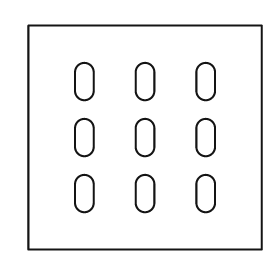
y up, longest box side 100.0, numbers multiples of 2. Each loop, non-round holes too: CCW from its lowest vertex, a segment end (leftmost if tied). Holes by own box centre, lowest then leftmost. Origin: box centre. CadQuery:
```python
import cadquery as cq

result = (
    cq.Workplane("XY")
    .moveTo(-50.0, -48.0)
    .lineTo(50.0, -48.0)
    .lineTo(50.0, 48.0)
    .lineTo(-50.0, 48.0)
    .close()
    .moveTo(-30.0, -28.0)
    .threePointArc((-26.0, -32.0), (-22.0, -28.0))
    .lineTo(-22.0, -20.0)
    .threePointArc((-26.0, -16.0), (-30.0, -20.0))
    .close()
    .moveTo(-4.0, -28.0)
    .threePointArc((0.0, -32.0), (4.0, -28.0))
    .lineTo(4.0, -20.0)
    .threePointArc((0.0, -16.0), (-4.0, -20.0))
    .close()
    .moveTo(22.0, -28.0)
    .threePointArc((26.0, -32.0), (30.0, -28.0))
    .lineTo(30.0, -20.0)
    .threePointArc((26.0, -16.0), (22.0, -20.0))
    .close()
    .moveTo(-30.0, -4.0)
    .threePointArc((-26.0, -8.0), (-22.0, -4.0))
    .lineTo(-22.0, 4.0)
    .threePointArc((-26.0, 8.0), (-30.0, 4.0))
    .close()
    .moveTo(-4.0, -4.0)
    .threePointArc((0.0, -8.0), (4.0, -4.0))
    .lineTo(4.0, 4.0)
    .threePointArc((0.0, 8.0), (-4.0, 4.0))
    .close()
    .moveTo(22.0, -4.0)
    .threePointArc((26.0, -8.0), (30.0, -4.0))
    .lineTo(30.0, 4.0)
    .threePointArc((26.0, 8.0), (22.0, 4.0))
    .close()
    .moveTo(-30.0, 20.0)
    .threePointArc((-26.0, 16.0), (-22.0, 20.0))
    .lineTo(-22.0, 28.0)
    .threePointArc((-26.0, 32.0), (-30.0, 28.0))
    .close()
    .moveTo(-4.0, 20.0)
    .threePointArc((0.0, 16.0), (4.0, 20.0))
    .lineTo(4.0, 28.0)
    .threePointArc((0.0, 32.0), (-4.0, 28.0))
    .close()
    .moveTo(22.0, 20.0)
    .threePointArc((26.0, 16.0), (30.0, 20.0))
    .lineTo(30.0, 28.0)
    .threePointArc((26.0, 32.0), (22.0, 28.0))
    .close()
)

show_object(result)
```